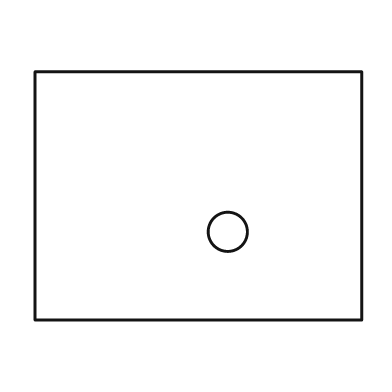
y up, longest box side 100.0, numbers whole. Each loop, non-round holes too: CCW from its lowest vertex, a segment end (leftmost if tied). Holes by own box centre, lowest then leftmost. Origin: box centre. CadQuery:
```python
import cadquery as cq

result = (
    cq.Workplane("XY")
    .moveTo(-50.0, -38.0)
    .lineTo(50.0, -38.0)
    .lineTo(50.0, 38.0)
    .lineTo(-50.0, 38.0)
    .close()
    .moveTo(9.0, -11.0)
    .circle(6.0)
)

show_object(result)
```